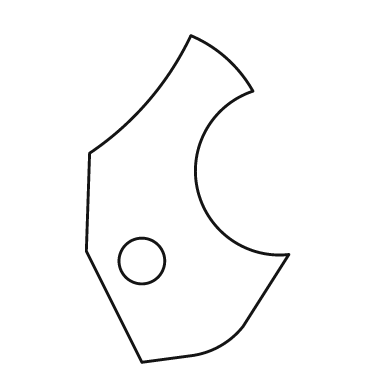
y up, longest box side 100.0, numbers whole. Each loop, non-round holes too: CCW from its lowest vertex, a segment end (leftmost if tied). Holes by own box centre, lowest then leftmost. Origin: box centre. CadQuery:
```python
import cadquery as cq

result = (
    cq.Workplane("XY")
    .moveTo(-14.0, -50.0)
    .lineTo(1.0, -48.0)
    .threePointArc((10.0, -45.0), (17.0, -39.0))
    .lineTo(31.0, -17.0)
    .threePointArc((3.0, 3.0), (20.0, 33.0))
    .threePointArc((12.0, 43.0), (1.0, 50.0))
    .threePointArc((-12.0, 30.0), (-30.0, 14.0))
    .lineTo(-31.0, -16.0)
    .close()
    .moveTo(-14.0, -19.0)
    .circle(7.0)
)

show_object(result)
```